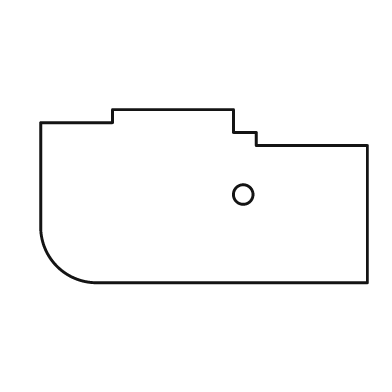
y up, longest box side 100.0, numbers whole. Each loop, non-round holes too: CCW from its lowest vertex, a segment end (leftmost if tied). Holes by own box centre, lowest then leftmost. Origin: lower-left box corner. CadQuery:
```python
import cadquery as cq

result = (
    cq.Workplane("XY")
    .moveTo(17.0, 0.0)
    .lineTo(100.0, 0.0)
    .lineTo(100.0, 42.0)
    .lineTo(66.0, 42.0)
    .lineTo(66.0, 46.0)
    .lineTo(59.0, 46.0)
    .lineTo(59.0, 53.0)
    .lineTo(22.0, 53.0)
    .lineTo(22.0, 49.0)
    .lineTo(0.0, 49.0)
    .lineTo(0.0, 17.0)
    .threePointArc((5.0, 5.0), (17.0, 0.0))
    .close()
    .moveTo(62.0, 27.0)
    .circle(3.0)
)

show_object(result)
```